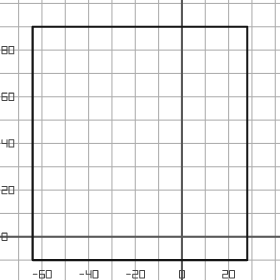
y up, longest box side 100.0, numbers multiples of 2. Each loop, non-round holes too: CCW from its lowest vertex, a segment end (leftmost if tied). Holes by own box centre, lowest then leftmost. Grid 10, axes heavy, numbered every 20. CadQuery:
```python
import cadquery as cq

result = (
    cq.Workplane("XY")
    .moveTo(-64.0, -10.0)
    .lineTo(28.0, -10.0)
    .lineTo(28.0, 90.0)
    .lineTo(-64.0, 90.0)
    .close()
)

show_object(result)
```